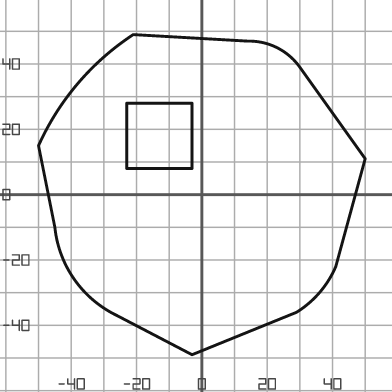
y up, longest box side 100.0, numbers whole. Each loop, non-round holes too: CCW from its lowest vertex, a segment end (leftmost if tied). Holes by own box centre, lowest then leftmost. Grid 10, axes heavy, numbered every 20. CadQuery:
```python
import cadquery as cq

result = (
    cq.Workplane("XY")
    .moveTo(-3.0, -49.0)
    .lineTo(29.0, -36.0)
    .threePointArc((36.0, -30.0), (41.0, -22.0))
    .lineTo(50.0, 11.0)
    .lineTo(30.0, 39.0)
    .threePointArc((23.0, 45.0), (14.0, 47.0))
    .lineTo(-21.0, 49.0)
    .threePointArc((-38.0, 34.0), (-50.0, 15.0))
    .lineTo(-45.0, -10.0)
    .threePointArc((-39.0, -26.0), (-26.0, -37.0))
    .close()
    .moveTo(-23.0, 8.0)
    .lineTo(-3.0, 8.0)
    .lineTo(-3.0, 28.0)
    .lineTo(-23.0, 28.0)
    .close()
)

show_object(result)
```